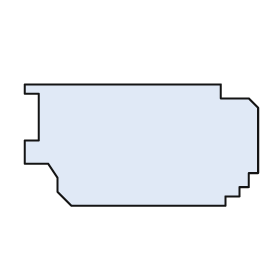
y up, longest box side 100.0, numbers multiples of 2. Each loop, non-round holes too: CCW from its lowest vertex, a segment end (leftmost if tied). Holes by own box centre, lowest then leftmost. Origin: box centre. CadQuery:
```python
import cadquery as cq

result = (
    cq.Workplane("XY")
    .moveTo(-30.0, -26.0)
    .lineTo(36.0, -26.0)
    .lineTo(36.0, -22.0)
    .lineTo(42.0, -22.0)
    .lineTo(42.0, -18.0)
    .lineTo(46.0, -18.0)
    .lineTo(46.0, -12.0)
    .lineTo(50.0, -12.0)
    .lineTo(50.0, 16.0)
    .lineTo(46.0, 20.0)
    .lineTo(34.0, 20.0)
    .lineTo(34.0, 26.0)
    .lineTo(-50.0, 26.0)
    .lineTo(-50.0, 22.0)
    .lineTo(-44.0, 22.0)
    .lineTo(-44.0, 2.0)
    .lineTo(-50.0, 2.0)
    .lineTo(-50.0, -8.0)
    .lineTo(-40.0, -8.0)
    .lineTo(-36.0, -14.0)
    .lineTo(-36.0, -20.0)
    .close()
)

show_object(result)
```